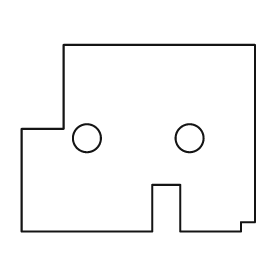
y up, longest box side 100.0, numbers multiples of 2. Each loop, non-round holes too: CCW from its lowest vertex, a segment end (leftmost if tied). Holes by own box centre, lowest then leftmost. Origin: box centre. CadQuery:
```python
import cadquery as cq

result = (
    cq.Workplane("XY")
    .moveTo(-50.0, -40.0)
    .lineTo(6.0, -40.0)
    .lineTo(6.0, -20.0)
    .lineTo(18.0, -20.0)
    .lineTo(18.0, -40.0)
    .lineTo(44.0, -40.0)
    .lineTo(44.0, -36.0)
    .lineTo(50.0, -36.0)
    .lineTo(50.0, 40.0)
    .lineTo(-32.0, 40.0)
    .lineTo(-32.0, 4.0)
    .lineTo(-50.0, 4.0)
    .close()
    .moveTo(-22.0, 0.0)
    .circle(6.0)
    .moveTo(22.0, 0.0)
    .circle(6.0)
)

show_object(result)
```